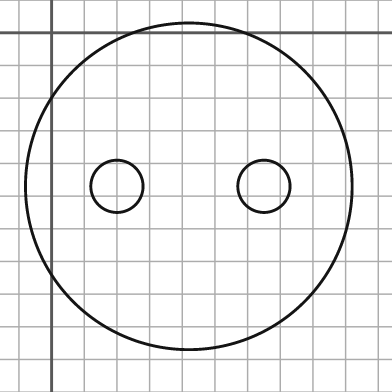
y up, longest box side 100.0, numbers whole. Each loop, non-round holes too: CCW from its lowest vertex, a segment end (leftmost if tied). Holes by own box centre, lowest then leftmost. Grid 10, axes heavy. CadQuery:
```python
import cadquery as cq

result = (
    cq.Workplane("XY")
    .moveTo(42.0, -47.0)
    .circle(50.0)
    .moveTo(20.0, -47.0)
    .circle(8.0)
    .moveTo(65.0, -47.0)
    .circle(8.0)
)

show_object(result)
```